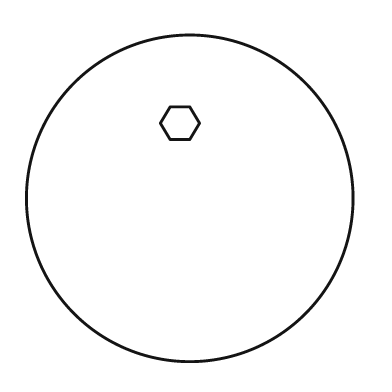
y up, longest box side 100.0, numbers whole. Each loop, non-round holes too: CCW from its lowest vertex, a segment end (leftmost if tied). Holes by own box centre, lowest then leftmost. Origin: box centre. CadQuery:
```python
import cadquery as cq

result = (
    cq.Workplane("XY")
    .moveTo(0.0, 0.0)
    .circle(50.0)
    .moveTo(-6.0, 18.0)
    .lineTo(0.0, 18.0)
    .lineTo(3.0, 23.0)
    .lineTo(0.0, 28.0)
    .lineTo(-6.0, 28.0)
    .lineTo(-9.0, 23.0)
    .close()
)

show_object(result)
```